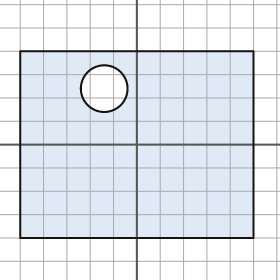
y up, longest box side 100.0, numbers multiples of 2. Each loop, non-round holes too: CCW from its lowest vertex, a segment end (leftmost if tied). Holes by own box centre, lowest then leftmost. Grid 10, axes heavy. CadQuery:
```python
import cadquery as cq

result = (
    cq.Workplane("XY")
    .moveTo(-50.0, -40.0)
    .lineTo(50.0, -40.0)
    .lineTo(50.0, 40.0)
    .lineTo(-50.0, 40.0)
    .close()
    .moveTo(-14.0, 24.0)
    .circle(10.0)
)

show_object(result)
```